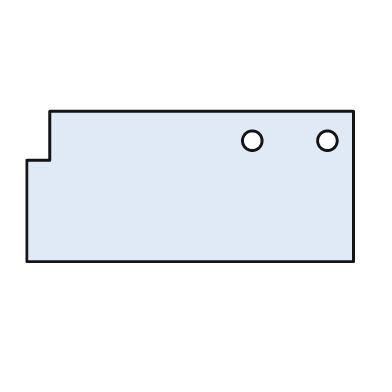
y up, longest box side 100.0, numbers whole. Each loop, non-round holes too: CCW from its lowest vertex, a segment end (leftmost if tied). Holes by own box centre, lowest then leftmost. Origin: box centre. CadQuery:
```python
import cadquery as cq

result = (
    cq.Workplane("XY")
    .moveTo(-50.0, -23.0)
    .lineTo(50.0, -23.0)
    .lineTo(50.0, 23.0)
    .lineTo(-43.0, 23.0)
    .lineTo(-43.0, 8.0)
    .lineTo(-50.0, 8.0)
    .close()
    .moveTo(19.0, 14.0)
    .circle(3.0)
    .moveTo(42.0, 14.0)
    .circle(3.0)
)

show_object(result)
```